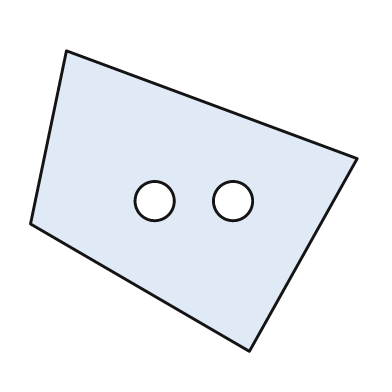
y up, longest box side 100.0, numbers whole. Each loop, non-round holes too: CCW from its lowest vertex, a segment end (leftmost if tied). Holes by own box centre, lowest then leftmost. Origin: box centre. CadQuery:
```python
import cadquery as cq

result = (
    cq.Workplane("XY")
    .moveTo(17.0, -46.0)
    .lineTo(50.0, 13.0)
    .lineTo(-39.0, 46.0)
    .lineTo(-50.0, -7.0)
    .close()
    .moveTo(-12.0, 0.0)
    .circle(6.0)
    .moveTo(12.0, 0.0)
    .circle(6.0)
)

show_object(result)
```